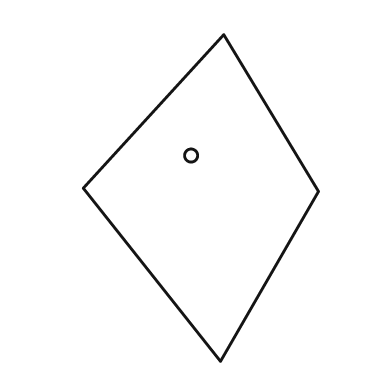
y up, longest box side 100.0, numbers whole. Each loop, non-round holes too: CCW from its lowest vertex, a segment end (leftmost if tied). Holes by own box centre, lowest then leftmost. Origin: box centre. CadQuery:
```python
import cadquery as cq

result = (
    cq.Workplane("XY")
    .moveTo(6.0, -50.0)
    .lineTo(36.0, 2.0)
    .lineTo(7.0, 50.0)
    .lineTo(-36.0, 3.0)
    .close()
    .moveTo(-3.0, 13.0)
    .circle(2.0)
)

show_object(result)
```